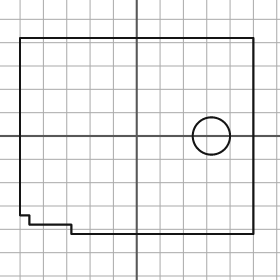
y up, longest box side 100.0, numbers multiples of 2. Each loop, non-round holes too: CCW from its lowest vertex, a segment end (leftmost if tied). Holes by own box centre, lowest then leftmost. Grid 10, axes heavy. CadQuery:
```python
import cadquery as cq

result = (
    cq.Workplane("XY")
    .moveTo(-28.0, -42.0)
    .lineTo(50.0, -42.0)
    .lineTo(50.0, 42.0)
    .lineTo(-50.0, 42.0)
    .lineTo(-50.0, -34.0)
    .lineTo(-46.0, -34.0)
    .lineTo(-46.0, -38.0)
    .lineTo(-28.0, -38.0)
    .close()
    .moveTo(32.0, 0.0)
    .circle(8.0)
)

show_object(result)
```